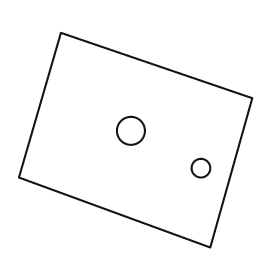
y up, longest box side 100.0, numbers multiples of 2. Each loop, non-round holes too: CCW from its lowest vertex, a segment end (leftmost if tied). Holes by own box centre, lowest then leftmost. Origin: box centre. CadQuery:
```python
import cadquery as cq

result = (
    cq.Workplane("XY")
    .moveTo(32.0, -46.0)
    .lineTo(50.0, 18.0)
    .lineTo(-32.0, 46.0)
    .lineTo(-50.0, -16.0)
    .close()
    .moveTo(28.0, -12.0)
    .circle(4.0)
    .moveTo(-2.0, 4.0)
    .circle(6.0)
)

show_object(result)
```